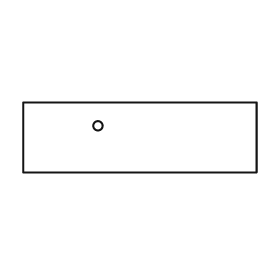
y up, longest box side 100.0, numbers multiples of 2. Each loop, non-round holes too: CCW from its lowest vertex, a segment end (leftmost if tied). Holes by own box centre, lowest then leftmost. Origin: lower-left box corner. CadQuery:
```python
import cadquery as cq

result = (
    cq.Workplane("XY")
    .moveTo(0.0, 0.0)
    .lineTo(100.0, 0.0)
    .lineTo(100.0, 30.0)
    .lineTo(0.0, 30.0)
    .close()
    .moveTo(32.0, 20.0)
    .circle(2.0)
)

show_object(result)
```